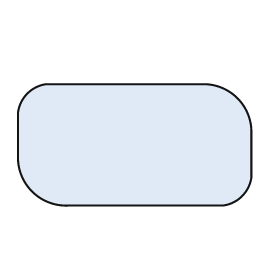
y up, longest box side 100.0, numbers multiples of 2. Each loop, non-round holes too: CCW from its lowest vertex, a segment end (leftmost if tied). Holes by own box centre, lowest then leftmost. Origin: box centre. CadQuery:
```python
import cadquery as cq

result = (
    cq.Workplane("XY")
    .moveTo(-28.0, -26.0)
    .lineTo(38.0, -26.0)
    .threePointArc((46.0, -22.0), (50.0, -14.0))
    .lineTo(50.0, 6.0)
    .threePointArc((44.0, 20.0), (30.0, 26.0))
    .lineTo(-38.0, 26.0)
    .threePointArc((-46.0, 22.0), (-50.0, 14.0))
    .lineTo(-50.0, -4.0)
    .threePointArc((-44.0, -20.0), (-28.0, -26.0))
    .close()
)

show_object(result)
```